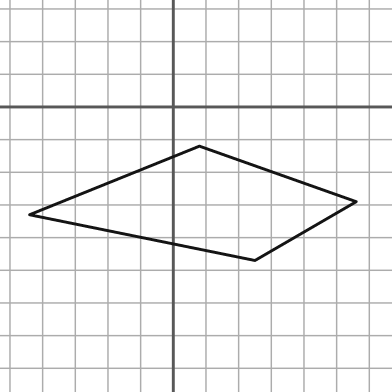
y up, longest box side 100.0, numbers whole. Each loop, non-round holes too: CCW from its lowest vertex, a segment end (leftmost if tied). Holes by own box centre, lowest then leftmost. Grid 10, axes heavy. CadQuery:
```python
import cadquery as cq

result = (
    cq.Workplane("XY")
    .moveTo(25.0, -47.0)
    .lineTo(56.0, -29.0)
    .lineTo(8.0, -12.0)
    .lineTo(-44.0, -33.0)
    .close()
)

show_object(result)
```